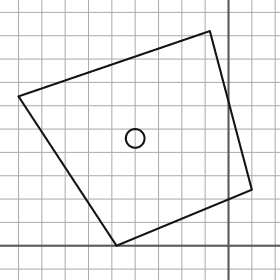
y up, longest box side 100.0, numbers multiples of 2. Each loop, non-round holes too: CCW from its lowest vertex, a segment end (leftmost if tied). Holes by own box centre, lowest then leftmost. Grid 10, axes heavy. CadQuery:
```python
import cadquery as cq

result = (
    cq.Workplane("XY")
    .moveTo(-48.0, 0.0)
    .lineTo(10.0, 24.0)
    .lineTo(-8.0, 92.0)
    .lineTo(-90.0, 64.0)
    .close()
    .moveTo(-40.0, 46.0)
    .circle(4.0)
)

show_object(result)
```